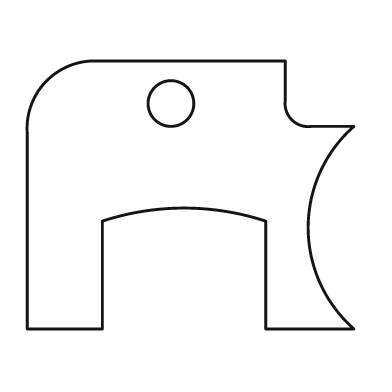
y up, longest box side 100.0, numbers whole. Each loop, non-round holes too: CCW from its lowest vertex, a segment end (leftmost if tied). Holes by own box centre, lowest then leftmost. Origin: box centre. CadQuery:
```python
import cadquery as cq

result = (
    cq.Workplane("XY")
    .moveTo(-50.0, -41.0)
    .lineTo(-27.0, -41.0)
    .lineTo(-27.0, -8.0)
    .threePointArc((-2.0, -4.0), (23.0, -8.0))
    .lineTo(23.0, -41.0)
    .lineTo(50.0, -41.0)
    .threePointArc((36.0, -10.0), (50.0, 21.0))
    .lineTo(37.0, 21.0)
    .threePointArc((31.0, 23.0), (29.0, 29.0))
    .lineTo(29.0, 41.0)
    .lineTo(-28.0, 41.0)
    .threePointArc((-44.0, 35.0), (-50.0, 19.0))
    .close()
    .moveTo(-6.0, 28.0)
    .circle(7.0)
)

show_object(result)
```